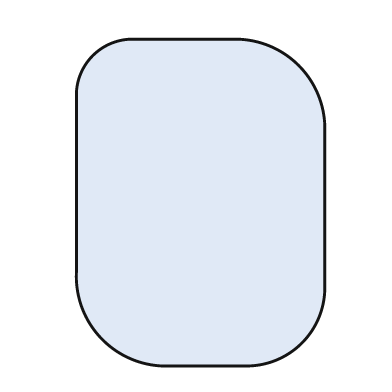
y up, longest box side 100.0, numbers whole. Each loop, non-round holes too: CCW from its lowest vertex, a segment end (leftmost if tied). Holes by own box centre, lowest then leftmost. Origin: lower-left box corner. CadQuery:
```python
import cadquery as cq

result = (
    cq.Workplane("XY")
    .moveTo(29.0, 0.0)
    .lineTo(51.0, 0.0)
    .threePointArc((69.0, 7.0), (76.0, 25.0))
    .lineTo(76.0, 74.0)
    .threePointArc((68.0, 92.0), (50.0, 100.0))
    .lineTo(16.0, 100.0)
    .threePointArc((5.0, 95.0), (0.0, 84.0))
    .lineTo(0.0, 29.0)
    .threePointArc((8.0, 8.0), (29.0, 0.0))
    .close()
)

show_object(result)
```